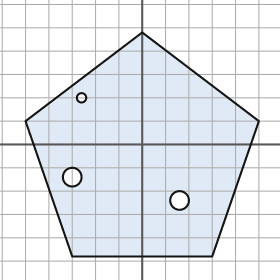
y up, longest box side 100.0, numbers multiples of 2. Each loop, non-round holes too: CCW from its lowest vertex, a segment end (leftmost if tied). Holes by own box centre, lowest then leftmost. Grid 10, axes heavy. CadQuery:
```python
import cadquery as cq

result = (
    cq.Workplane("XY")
    .moveTo(-30.0, -48.0)
    .lineTo(30.0, -48.0)
    .lineTo(50.0, 10.0)
    .lineTo(0.0, 48.0)
    .lineTo(-50.0, 10.0)
    .close()
    .moveTo(16.0, -24.0)
    .circle(4.0)
    .moveTo(-30.0, -14.0)
    .circle(4.0)
    .moveTo(-26.0, 20.0)
    .circle(2.0)
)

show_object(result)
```